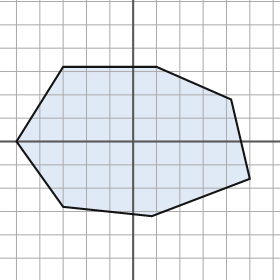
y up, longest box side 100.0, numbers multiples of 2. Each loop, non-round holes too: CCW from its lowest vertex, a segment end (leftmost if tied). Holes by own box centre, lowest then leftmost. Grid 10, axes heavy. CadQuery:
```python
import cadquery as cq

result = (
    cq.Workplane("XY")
    .moveTo(8.0, -32.0)
    .lineTo(50.0, -16.0)
    .lineTo(42.0, 18.0)
    .lineTo(10.0, 32.0)
    .lineTo(-30.0, 32.0)
    .lineTo(-50.0, 0.0)
    .lineTo(-30.0, -28.0)
    .close()
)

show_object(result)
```